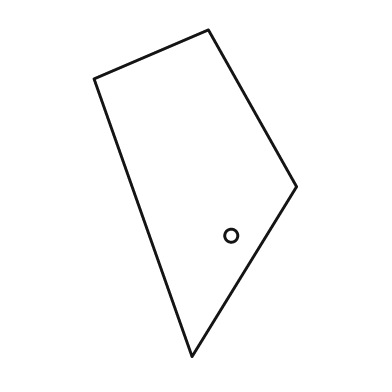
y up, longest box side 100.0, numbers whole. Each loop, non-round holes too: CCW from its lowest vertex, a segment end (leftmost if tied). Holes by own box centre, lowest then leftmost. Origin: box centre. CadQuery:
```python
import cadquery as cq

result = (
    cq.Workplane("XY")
    .moveTo(-1.0, -50.0)
    .lineTo(31.0, 2.0)
    .lineTo(4.0, 50.0)
    .lineTo(-31.0, 35.0)
    .close()
    .moveTo(11.0, -13.0)
    .circle(2.0)
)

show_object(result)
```